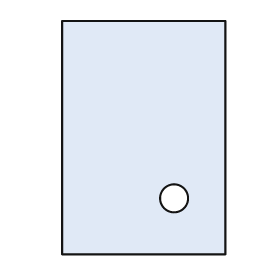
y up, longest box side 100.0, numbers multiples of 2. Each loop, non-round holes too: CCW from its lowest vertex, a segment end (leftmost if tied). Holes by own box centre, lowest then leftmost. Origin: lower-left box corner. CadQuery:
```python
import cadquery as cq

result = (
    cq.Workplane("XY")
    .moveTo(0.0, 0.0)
    .lineTo(70.0, 0.0)
    .lineTo(70.0, 100.0)
    .lineTo(0.0, 100.0)
    .close()
    .moveTo(48.0, 24.0)
    .circle(6.0)
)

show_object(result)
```